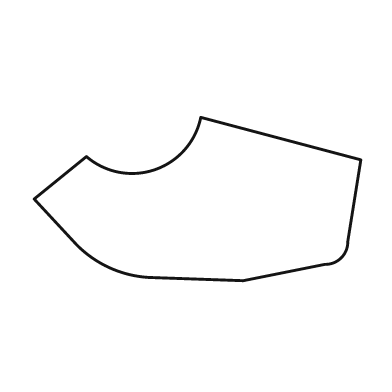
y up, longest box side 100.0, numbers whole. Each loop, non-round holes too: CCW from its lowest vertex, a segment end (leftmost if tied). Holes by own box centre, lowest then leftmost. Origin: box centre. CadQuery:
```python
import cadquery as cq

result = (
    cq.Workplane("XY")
    .moveTo(14.0, -25.0)
    .lineTo(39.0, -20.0)
    .threePointArc((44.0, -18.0), (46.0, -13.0))
    .lineTo(50.0, 12.0)
    .lineTo(1.0, 25.0)
    .threePointArc((-13.0, 9.0), (-34.0, 13.0))
    .lineTo(-50.0, 0.0)
    .lineTo(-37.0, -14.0)
    .threePointArc((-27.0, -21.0), (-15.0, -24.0))
    .close()
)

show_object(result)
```